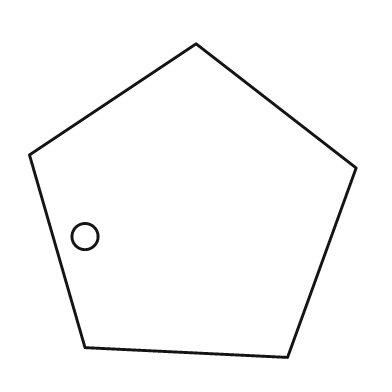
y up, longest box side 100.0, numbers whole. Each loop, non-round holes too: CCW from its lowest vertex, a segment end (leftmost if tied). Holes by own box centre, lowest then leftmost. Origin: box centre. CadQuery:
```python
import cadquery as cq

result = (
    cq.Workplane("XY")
    .moveTo(29.0, -48.0)
    .lineTo(50.0, 10.0)
    .lineTo(1.0, 48.0)
    .lineTo(-50.0, 14.0)
    .lineTo(-33.0, -45.0)
    .close()
    .moveTo(-33.0, -11.0)
    .circle(4.0)
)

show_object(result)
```